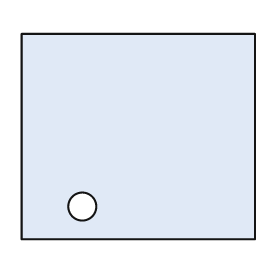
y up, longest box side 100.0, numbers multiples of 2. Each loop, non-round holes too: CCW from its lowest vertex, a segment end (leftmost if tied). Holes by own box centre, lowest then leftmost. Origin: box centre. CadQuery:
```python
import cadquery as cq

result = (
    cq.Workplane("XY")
    .moveTo(-50.0, -44.0)
    .lineTo(50.0, -44.0)
    .lineTo(50.0, 44.0)
    .lineTo(-50.0, 44.0)
    .close()
    .moveTo(-24.0, -30.0)
    .circle(6.0)
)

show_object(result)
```